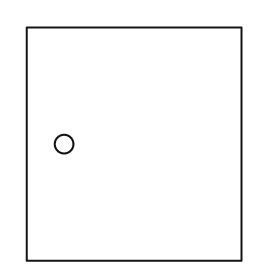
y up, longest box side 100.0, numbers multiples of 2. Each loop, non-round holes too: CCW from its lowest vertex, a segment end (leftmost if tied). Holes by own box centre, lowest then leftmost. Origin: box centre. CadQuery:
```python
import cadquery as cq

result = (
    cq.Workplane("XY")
    .moveTo(-46.0, -50.0)
    .lineTo(46.0, -50.0)
    .lineTo(46.0, 50.0)
    .lineTo(-46.0, 50.0)
    .close()
    .moveTo(-30.0, 0.0)
    .circle(4.0)
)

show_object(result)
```